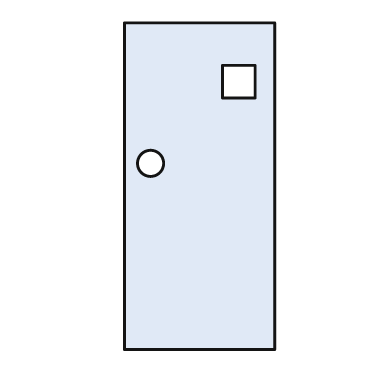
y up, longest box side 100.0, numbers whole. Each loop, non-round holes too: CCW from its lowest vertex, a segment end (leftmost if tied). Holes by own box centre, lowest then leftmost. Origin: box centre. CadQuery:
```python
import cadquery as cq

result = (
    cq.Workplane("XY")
    .moveTo(-23.0, -50.0)
    .lineTo(23.0, -50.0)
    .lineTo(23.0, 50.0)
    .lineTo(-23.0, 50.0)
    .close()
    .moveTo(-15.0, 7.0)
    .circle(4.0)
    .moveTo(7.0, 27.0)
    .lineTo(17.0, 27.0)
    .lineTo(17.0, 37.0)
    .lineTo(7.0, 37.0)
    .close()
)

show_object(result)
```